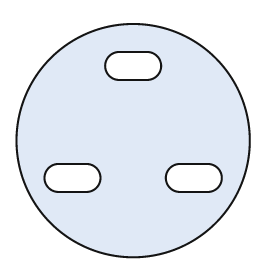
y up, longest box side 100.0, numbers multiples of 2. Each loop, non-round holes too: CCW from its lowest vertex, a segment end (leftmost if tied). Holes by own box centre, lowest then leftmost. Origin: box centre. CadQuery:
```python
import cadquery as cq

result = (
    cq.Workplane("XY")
    .moveTo(0.0, 0.0)
    .circle(50.0)
    .moveTo(-32.0, -22.0)
    .lineTo(-20.0, -22.0)
    .threePointArc((-14.0, -16.0), (-20.0, -10.0))
    .lineTo(-32.0, -10.0)
    .threePointArc((-38.0, -16.0), (-32.0, -22.0))
    .close()
    .moveTo(20.0, -22.0)
    .lineTo(32.0, -22.0)
    .threePointArc((38.0, -16.0), (32.0, -10.0))
    .lineTo(20.0, -10.0)
    .threePointArc((14.0, -16.0), (20.0, -22.0))
    .close()
    .moveTo(-6.0, 26.0)
    .lineTo(6.0, 26.0)
    .threePointArc((12.0, 32.0), (6.0, 38.0))
    .lineTo(-6.0, 38.0)
    .threePointArc((-12.0, 32.0), (-6.0, 26.0))
    .close()
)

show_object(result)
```